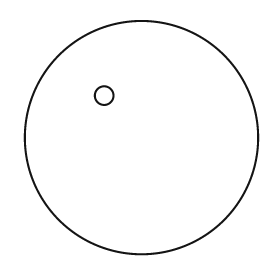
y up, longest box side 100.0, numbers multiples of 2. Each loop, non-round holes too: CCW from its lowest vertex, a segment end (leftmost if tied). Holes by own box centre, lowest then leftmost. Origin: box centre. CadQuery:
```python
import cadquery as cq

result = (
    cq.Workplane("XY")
    .moveTo(0.0, 0.0)
    .circle(50.0)
    .moveTo(-16.0, 18.0)
    .circle(4.0)
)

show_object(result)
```